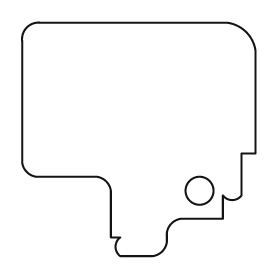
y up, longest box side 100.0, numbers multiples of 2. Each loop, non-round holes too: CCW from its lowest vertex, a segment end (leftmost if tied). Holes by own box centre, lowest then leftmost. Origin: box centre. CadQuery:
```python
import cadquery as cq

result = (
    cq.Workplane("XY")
    .moveTo(-8.0, -50.0)
    .lineTo(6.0, -50.0)
    .threePointArc((10.0, -48.0), (12.0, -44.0))
    .lineTo(12.0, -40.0)
    .threePointArc((14.0, -36.0), (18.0, -34.0))
    .lineTo(36.0, -34.0)
    .lineTo(36.0, -24.0)
    .threePointArc((40.0, -26.0), (44.0, -24.0))
    .lineTo(44.0, -6.0)
    .lineTo(50.0, -6.0)
    .lineTo(50.0, 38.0)
    .threePointArc((46.0, 46.0), (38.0, 50.0))
    .lineTo(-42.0, 50.0)
    .threePointArc((-48.0, 48.0), (-50.0, 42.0))
    .lineTo(-50.0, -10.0)
    .threePointArc((-48.0, -14.0), (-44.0, -16.0))
    .lineTo(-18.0, -16.0)
    .threePointArc((-14.0, -18.0), (-12.0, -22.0))
    .lineTo(-12.0, -42.0)
    .lineTo(-8.0, -42.0)
    .threePointArc((-10.0, -46.0), (-8.0, -50.0))
    .close()
    .moveTo(26.0, -22.0)
    .circle(6.0)
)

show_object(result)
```